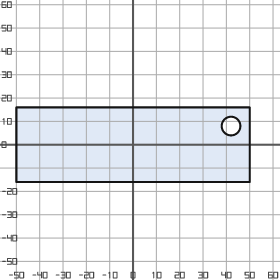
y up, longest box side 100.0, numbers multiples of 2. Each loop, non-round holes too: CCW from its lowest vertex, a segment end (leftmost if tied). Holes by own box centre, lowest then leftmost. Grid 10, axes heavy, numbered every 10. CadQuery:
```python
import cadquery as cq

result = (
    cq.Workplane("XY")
    .moveTo(-50.0, -16.0)
    .lineTo(50.0, -16.0)
    .lineTo(50.0, 16.0)
    .lineTo(-50.0, 16.0)
    .close()
    .moveTo(42.0, 8.0)
    .circle(4.0)
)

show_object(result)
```